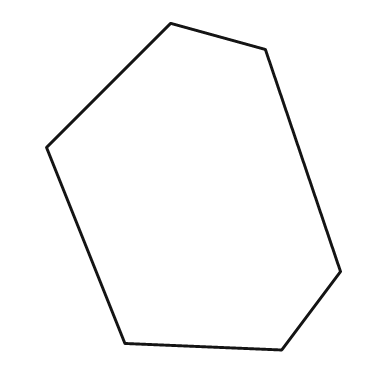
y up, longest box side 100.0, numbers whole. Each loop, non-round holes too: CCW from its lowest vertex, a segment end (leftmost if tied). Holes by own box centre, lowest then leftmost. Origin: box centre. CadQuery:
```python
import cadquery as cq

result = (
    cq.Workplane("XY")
    .moveTo(27.0, -50.0)
    .lineTo(45.0, -26.0)
    .lineTo(22.0, 42.0)
    .lineTo(-7.0, 50.0)
    .lineTo(-45.0, 12.0)
    .lineTo(-21.0, -48.0)
    .close()
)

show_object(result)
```